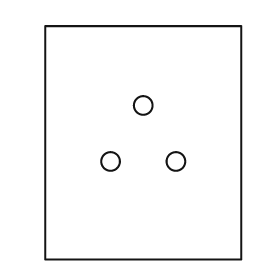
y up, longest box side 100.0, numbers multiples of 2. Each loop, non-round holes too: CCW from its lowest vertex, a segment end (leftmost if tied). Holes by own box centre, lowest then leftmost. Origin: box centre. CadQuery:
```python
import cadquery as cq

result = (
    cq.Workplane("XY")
    .moveTo(-42.0, -50.0)
    .lineTo(42.0, -50.0)
    .lineTo(42.0, 50.0)
    .lineTo(-42.0, 50.0)
    .close()
    .moveTo(-14.0, -8.0)
    .circle(4.0)
    .moveTo(14.0, -8.0)
    .circle(4.0)
    .moveTo(0.0, 16.0)
    .circle(4.0)
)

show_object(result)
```